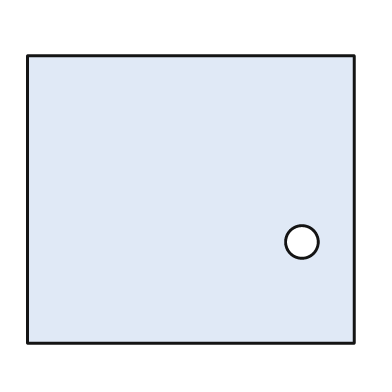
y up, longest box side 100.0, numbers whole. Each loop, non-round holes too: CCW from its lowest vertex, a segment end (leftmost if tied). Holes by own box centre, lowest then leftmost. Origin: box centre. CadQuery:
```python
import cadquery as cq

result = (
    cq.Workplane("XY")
    .moveTo(-50.0, -44.0)
    .lineTo(50.0, -44.0)
    .lineTo(50.0, 44.0)
    .lineTo(-50.0, 44.0)
    .close()
    .moveTo(34.0, -13.0)
    .circle(5.0)
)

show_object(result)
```